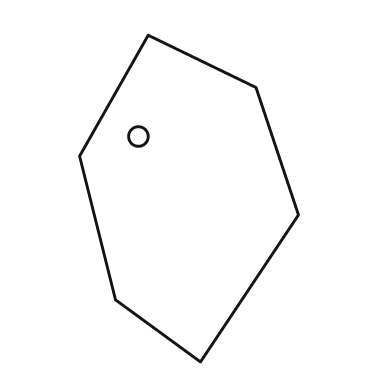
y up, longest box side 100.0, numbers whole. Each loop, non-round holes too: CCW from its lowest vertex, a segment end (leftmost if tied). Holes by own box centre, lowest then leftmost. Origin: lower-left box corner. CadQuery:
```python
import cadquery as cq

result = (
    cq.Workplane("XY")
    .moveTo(37.0, 0.0)
    .lineTo(67.0, 45.0)
    .lineTo(54.0, 84.0)
    .lineTo(21.0, 100.0)
    .lineTo(0.0, 63.0)
    .lineTo(11.0, 19.0)
    .close()
    .moveTo(18.0, 69.0)
    .circle(3.0)
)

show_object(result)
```